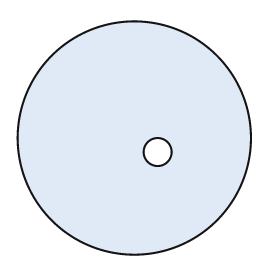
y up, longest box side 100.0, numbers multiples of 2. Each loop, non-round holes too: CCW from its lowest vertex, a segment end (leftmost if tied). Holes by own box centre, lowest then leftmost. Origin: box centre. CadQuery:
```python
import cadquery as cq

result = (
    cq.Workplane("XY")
    .moveTo(0.0, 0.0)
    .circle(50.0)
    .moveTo(10.0, -6.0)
    .circle(6.0)
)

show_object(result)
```